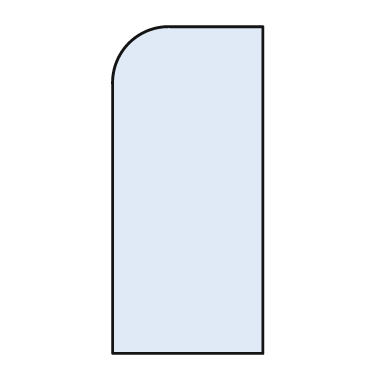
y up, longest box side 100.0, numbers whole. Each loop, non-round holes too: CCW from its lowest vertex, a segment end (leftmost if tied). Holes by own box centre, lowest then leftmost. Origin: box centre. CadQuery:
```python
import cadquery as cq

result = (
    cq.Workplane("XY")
    .moveTo(-23.0, -50.0)
    .lineTo(23.0, -50.0)
    .lineTo(23.0, 50.0)
    .lineTo(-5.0, 50.0)
    .threePointArc((-18.0, 45.0), (-23.0, 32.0))
    .close()
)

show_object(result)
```